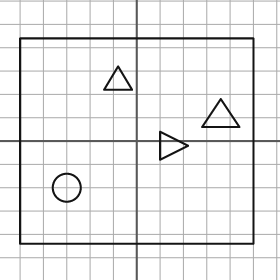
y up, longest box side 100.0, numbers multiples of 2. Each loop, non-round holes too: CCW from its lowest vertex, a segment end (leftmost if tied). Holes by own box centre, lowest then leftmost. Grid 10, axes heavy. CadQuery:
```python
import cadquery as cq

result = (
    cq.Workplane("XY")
    .moveTo(-50.0, -44.0)
    .lineTo(50.0, -44.0)
    .lineTo(50.0, 44.0)
    .lineTo(-50.0, 44.0)
    .close()
    .moveTo(-30.0, -20.0)
    .circle(6.0)
    .moveTo(10.0, -8.0)
    .lineTo(22.0, -2.0)
    .lineTo(10.0, 4.0)
    .close()
    .moveTo(28.0, 6.0)
    .lineTo(44.0, 6.0)
    .lineTo(36.0, 18.0)
    .close()
    .moveTo(-14.0, 22.0)
    .lineTo(-2.0, 22.0)
    .lineTo(-8.0, 32.0)
    .close()
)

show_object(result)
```